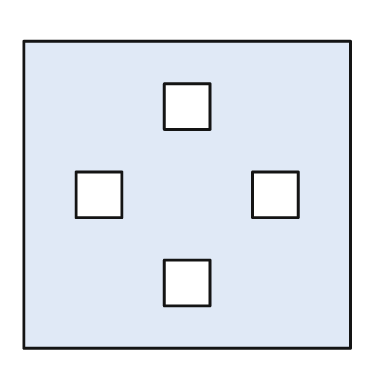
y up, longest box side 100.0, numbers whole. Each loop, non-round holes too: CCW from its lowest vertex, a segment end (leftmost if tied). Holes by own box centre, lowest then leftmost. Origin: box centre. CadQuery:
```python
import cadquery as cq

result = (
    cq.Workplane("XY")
    .moveTo(-50.0, -47.0)
    .lineTo(50.0, -47.0)
    .lineTo(50.0, 47.0)
    .lineTo(-50.0, 47.0)
    .close()
    .moveTo(-7.0, -34.0)
    .lineTo(7.0, -34.0)
    .lineTo(7.0, -20.0)
    .lineTo(-7.0, -20.0)
    .close()
    .moveTo(-34.0, -7.0)
    .lineTo(-20.0, -7.0)
    .lineTo(-20.0, 7.0)
    .lineTo(-34.0, 7.0)
    .close()
    .moveTo(20.0, -7.0)
    .lineTo(34.0, -7.0)
    .lineTo(34.0, 7.0)
    .lineTo(20.0, 7.0)
    .close()
    .moveTo(-7.0, 20.0)
    .lineTo(7.0, 20.0)
    .lineTo(7.0, 34.0)
    .lineTo(-7.0, 34.0)
    .close()
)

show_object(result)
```